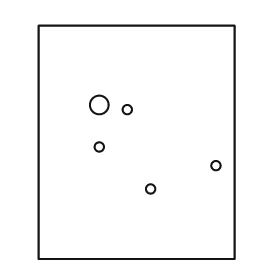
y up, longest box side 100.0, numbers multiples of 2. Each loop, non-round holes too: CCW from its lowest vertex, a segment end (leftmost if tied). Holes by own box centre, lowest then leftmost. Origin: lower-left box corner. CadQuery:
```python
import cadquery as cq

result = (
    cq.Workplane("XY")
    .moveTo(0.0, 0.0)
    .lineTo(84.0, 0.0)
    .lineTo(84.0, 100.0)
    .lineTo(0.0, 100.0)
    .close()
    .moveTo(48.0, 30.0)
    .circle(2.0)
    .moveTo(76.0, 40.0)
    .circle(2.0)
    .moveTo(26.0, 48.0)
    .circle(2.0)
    .moveTo(38.0, 64.0)
    .circle(2.0)
    .moveTo(26.0, 66.0)
    .circle(4.0)
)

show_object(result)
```